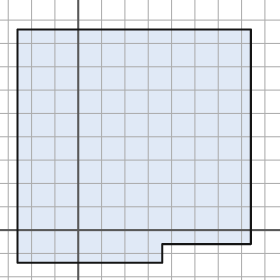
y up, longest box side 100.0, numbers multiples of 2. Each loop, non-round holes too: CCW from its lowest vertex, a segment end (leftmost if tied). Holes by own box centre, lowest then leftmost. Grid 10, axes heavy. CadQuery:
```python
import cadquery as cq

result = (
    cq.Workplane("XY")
    .moveTo(-26.0, -14.0)
    .lineTo(36.0, -14.0)
    .lineTo(36.0, -6.0)
    .lineTo(74.0, -6.0)
    .lineTo(74.0, 86.0)
    .lineTo(-26.0, 86.0)
    .close()
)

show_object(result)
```